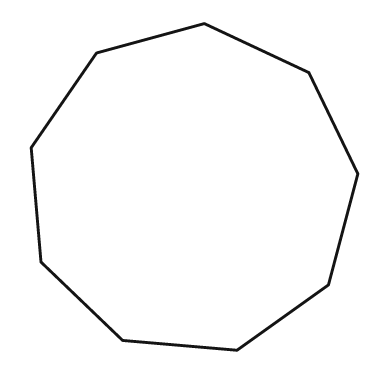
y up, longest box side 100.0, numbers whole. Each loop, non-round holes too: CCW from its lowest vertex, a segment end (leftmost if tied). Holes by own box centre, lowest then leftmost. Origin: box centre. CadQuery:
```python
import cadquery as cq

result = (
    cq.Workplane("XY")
    .moveTo(13.0, -50.0)
    .lineTo(41.0, -30.0)
    .lineTo(50.0, 4.0)
    .lineTo(35.0, 35.0)
    .lineTo(3.0, 50.0)
    .lineTo(-30.0, 41.0)
    .lineTo(-50.0, 12.0)
    .lineTo(-47.0, -23.0)
    .lineTo(-22.0, -47.0)
    .close()
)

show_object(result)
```